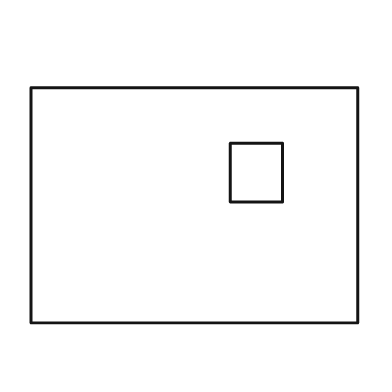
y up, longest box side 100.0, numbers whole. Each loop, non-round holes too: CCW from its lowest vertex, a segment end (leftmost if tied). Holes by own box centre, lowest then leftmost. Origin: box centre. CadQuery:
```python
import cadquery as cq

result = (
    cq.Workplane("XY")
    .moveTo(-50.0, -36.0)
    .lineTo(50.0, -36.0)
    .lineTo(50.0, 36.0)
    .lineTo(-50.0, 36.0)
    .close()
    .moveTo(11.0, 1.0)
    .lineTo(27.0, 1.0)
    .lineTo(27.0, 19.0)
    .lineTo(11.0, 19.0)
    .close()
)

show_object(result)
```